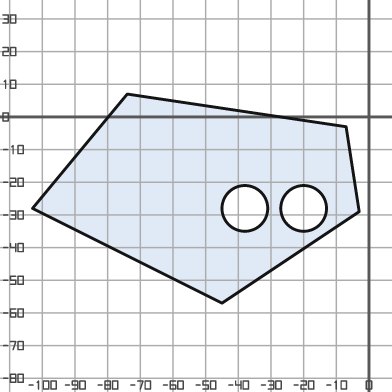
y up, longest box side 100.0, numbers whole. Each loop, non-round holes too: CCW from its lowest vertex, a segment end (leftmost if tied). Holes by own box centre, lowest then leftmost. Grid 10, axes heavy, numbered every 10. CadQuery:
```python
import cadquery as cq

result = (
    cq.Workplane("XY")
    .moveTo(-45.0, -57.0)
    .lineTo(-3.0, -29.0)
    .lineTo(-7.0, -3.0)
    .lineTo(-74.0, 7.0)
    .lineTo(-103.0, -28.0)
    .close()
    .moveTo(-38.0, -28.0)
    .circle(7.0)
    .moveTo(-20.0, -28.0)
    .circle(7.0)
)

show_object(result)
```